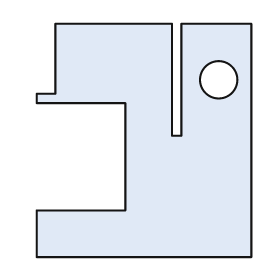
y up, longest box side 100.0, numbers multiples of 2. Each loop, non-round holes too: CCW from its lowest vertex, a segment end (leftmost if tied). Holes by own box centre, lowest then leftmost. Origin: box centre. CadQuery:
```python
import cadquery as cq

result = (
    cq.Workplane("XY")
    .moveTo(-46.0, -50.0)
    .lineTo(46.0, -50.0)
    .lineTo(46.0, 50.0)
    .lineTo(16.0, 50.0)
    .lineTo(16.0, 2.0)
    .lineTo(12.0, 2.0)
    .lineTo(12.0, 50.0)
    .lineTo(-38.0, 50.0)
    .lineTo(-38.0, 20.0)
    .lineTo(-46.0, 20.0)
    .lineTo(-46.0, 16.0)
    .lineTo(-8.0, 16.0)
    .lineTo(-8.0, -30.0)
    .lineTo(-46.0, -30.0)
    .close()
    .moveTo(32.0, 26.0)
    .circle(8.0)
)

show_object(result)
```